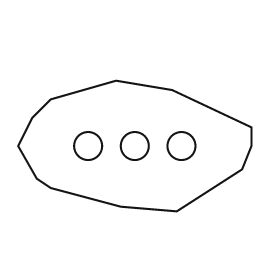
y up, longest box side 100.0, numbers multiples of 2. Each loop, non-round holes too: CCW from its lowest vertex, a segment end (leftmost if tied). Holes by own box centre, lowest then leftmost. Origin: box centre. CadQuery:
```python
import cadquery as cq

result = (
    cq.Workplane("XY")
    .moveTo(18.0, -28.0)
    .lineTo(46.0, -10.0)
    .lineTo(50.0, 0.0)
    .lineTo(50.0, 8.0)
    .lineTo(16.0, 24.0)
    .lineTo(-8.0, 28.0)
    .lineTo(-36.0, 20.0)
    .lineTo(-44.0, 12.0)
    .lineTo(-50.0, 0.0)
    .lineTo(-42.0, -14.0)
    .lineTo(-36.0, -18.0)
    .lineTo(-6.0, -26.0)
    .close()
    .moveTo(-20.0, 0.0)
    .circle(6.0)
    .moveTo(0.0, 0.0)
    .circle(6.0)
    .moveTo(20.0, 0.0)
    .circle(6.0)
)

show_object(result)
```